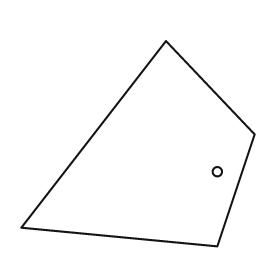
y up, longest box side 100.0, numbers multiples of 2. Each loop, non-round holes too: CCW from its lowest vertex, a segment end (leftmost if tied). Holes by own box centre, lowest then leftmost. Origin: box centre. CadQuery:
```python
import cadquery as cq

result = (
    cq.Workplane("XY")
    .moveTo(34.0, -44.0)
    .lineTo(50.0, 4.0)
    .lineTo(12.0, 44.0)
    .lineTo(-50.0, -36.0)
    .close()
    .moveTo(34.0, -12.0)
    .circle(2.0)
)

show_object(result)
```